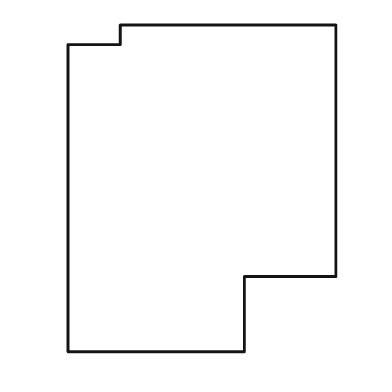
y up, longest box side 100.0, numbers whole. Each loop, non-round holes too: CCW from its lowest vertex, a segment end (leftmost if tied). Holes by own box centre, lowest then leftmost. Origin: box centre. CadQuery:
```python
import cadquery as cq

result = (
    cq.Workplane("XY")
    .moveTo(-41.0, -50.0)
    .lineTo(13.0, -50.0)
    .lineTo(13.0, -27.0)
    .lineTo(41.0, -27.0)
    .lineTo(41.0, 50.0)
    .lineTo(-25.0, 50.0)
    .lineTo(-25.0, 44.0)
    .lineTo(-41.0, 44.0)
    .close()
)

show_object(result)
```